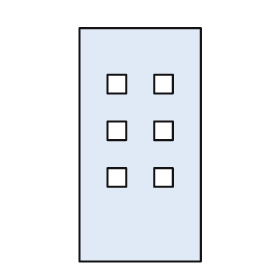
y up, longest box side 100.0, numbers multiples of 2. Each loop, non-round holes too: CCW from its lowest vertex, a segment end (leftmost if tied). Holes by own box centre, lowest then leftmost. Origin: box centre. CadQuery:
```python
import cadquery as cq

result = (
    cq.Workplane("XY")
    .moveTo(-26.0, -50.0)
    .lineTo(26.0, -50.0)
    .lineTo(26.0, 50.0)
    .lineTo(-26.0, 50.0)
    .close()
    .moveTo(-14.0, -18.0)
    .lineTo(-6.0, -18.0)
    .lineTo(-6.0, -10.0)
    .lineTo(-14.0, -10.0)
    .close()
    .moveTo(6.0, -18.0)
    .lineTo(14.0, -18.0)
    .lineTo(14.0, -10.0)
    .lineTo(6.0, -10.0)
    .close()
    .moveTo(-14.0, 2.0)
    .lineTo(-6.0, 2.0)
    .lineTo(-6.0, 10.0)
    .lineTo(-14.0, 10.0)
    .close()
    .moveTo(6.0, 2.0)
    .lineTo(14.0, 2.0)
    .lineTo(14.0, 10.0)
    .lineTo(6.0, 10.0)
    .close()
    .moveTo(-14.0, 22.0)
    .lineTo(-6.0, 22.0)
    .lineTo(-6.0, 30.0)
    .lineTo(-14.0, 30.0)
    .close()
    .moveTo(6.0, 22.0)
    .lineTo(14.0, 22.0)
    .lineTo(14.0, 30.0)
    .lineTo(6.0, 30.0)
    .close()
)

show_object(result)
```